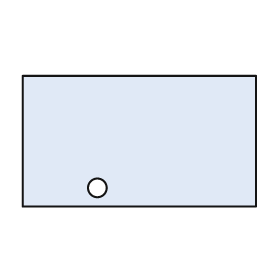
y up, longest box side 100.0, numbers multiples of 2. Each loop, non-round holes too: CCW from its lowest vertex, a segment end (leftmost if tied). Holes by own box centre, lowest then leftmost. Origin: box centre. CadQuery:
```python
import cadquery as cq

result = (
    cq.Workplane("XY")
    .moveTo(-50.0, -28.0)
    .lineTo(50.0, -28.0)
    .lineTo(50.0, 28.0)
    .lineTo(-50.0, 28.0)
    .close()
    .moveTo(-18.0, -20.0)
    .circle(4.0)
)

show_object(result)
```